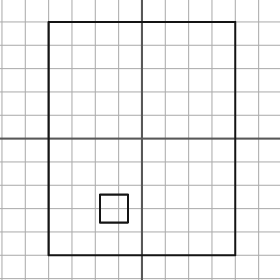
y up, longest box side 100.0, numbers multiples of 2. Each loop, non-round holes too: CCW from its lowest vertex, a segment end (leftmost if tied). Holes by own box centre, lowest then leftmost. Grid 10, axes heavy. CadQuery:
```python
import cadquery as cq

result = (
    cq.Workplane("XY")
    .moveTo(-40.0, -50.0)
    .lineTo(40.0, -50.0)
    .lineTo(40.0, 50.0)
    .lineTo(-40.0, 50.0)
    .close()
    .moveTo(-18.0, -36.0)
    .lineTo(-6.0, -36.0)
    .lineTo(-6.0, -24.0)
    .lineTo(-18.0, -24.0)
    .close()
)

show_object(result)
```